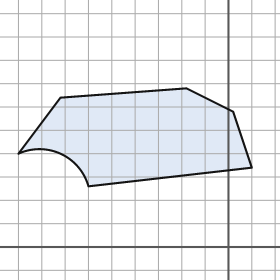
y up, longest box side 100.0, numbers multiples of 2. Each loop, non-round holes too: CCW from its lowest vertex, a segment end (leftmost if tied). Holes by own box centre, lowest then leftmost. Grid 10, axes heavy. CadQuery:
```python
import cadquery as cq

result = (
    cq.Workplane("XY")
    .moveTo(-60.0, 26.0)
    .lineTo(10.0, 34.0)
    .lineTo(2.0, 58.0)
    .lineTo(-18.0, 68.0)
    .lineTo(-72.0, 64.0)
    .lineTo(-90.0, 40.0)
    .threePointArc((-72.0, 40.0), (-60.0, 26.0))
    .close()
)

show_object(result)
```